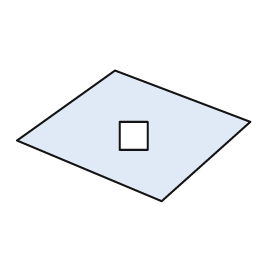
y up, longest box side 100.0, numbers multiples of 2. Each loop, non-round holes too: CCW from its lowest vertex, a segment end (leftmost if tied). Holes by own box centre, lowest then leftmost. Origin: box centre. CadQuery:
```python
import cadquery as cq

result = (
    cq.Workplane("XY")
    .moveTo(12.0, -28.0)
    .lineTo(50.0, 6.0)
    .lineTo(-8.0, 28.0)
    .lineTo(-50.0, -2.0)
    .close()
    .moveTo(-6.0, -6.0)
    .lineTo(6.0, -6.0)
    .lineTo(6.0, 6.0)
    .lineTo(-6.0, 6.0)
    .close()
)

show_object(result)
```